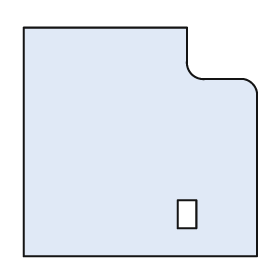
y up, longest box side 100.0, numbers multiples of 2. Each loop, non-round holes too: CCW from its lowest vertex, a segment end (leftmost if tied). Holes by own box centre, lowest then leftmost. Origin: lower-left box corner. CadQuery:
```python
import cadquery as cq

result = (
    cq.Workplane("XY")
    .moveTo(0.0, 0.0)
    .lineTo(100.0, 0.0)
    .lineTo(100.0, 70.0)
    .threePointArc((98.0, 74.0), (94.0, 76.0))
    .lineTo(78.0, 76.0)
    .threePointArc((72.0, 78.0), (70.0, 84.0))
    .lineTo(70.0, 98.0)
    .lineTo(0.0, 98.0)
    .close()
    .moveTo(66.0, 12.0)
    .lineTo(74.0, 12.0)
    .lineTo(74.0, 24.0)
    .lineTo(66.0, 24.0)
    .close()
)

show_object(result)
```